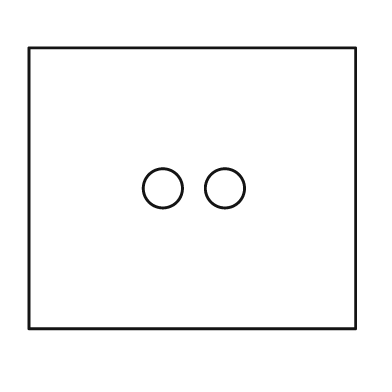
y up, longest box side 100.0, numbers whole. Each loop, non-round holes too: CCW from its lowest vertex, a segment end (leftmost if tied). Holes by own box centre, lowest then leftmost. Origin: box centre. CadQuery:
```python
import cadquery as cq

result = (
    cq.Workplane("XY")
    .moveTo(-50.0, -43.0)
    .lineTo(50.0, -43.0)
    .lineTo(50.0, 43.0)
    .lineTo(-50.0, 43.0)
    .close()
    .moveTo(-9.0, 0.0)
    .circle(6.0)
    .moveTo(10.0, 0.0)
    .circle(6.0)
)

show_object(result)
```